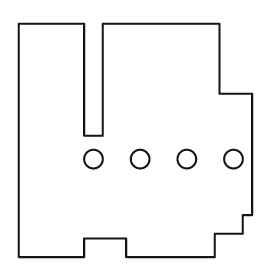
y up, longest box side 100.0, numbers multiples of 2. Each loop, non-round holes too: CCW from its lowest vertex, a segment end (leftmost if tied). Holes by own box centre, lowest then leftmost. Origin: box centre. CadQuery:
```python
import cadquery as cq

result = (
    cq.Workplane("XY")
    .moveTo(-50.0, -50.0)
    .lineTo(-22.0, -50.0)
    .lineTo(-22.0, -42.0)
    .lineTo(-4.0, -42.0)
    .lineTo(-4.0, -50.0)
    .lineTo(34.0, -50.0)
    .lineTo(34.0, -40.0)
    .lineTo(46.0, -40.0)
    .lineTo(46.0, -32.0)
    .lineTo(50.0, -32.0)
    .lineTo(50.0, 20.0)
    .lineTo(36.0, 20.0)
    .lineTo(36.0, 50.0)
    .lineTo(-14.0, 50.0)
    .lineTo(-14.0, 2.0)
    .lineTo(-22.0, 2.0)
    .lineTo(-22.0, 50.0)
    .lineTo(-50.0, 50.0)
    .close()
    .moveTo(-18.0, -8.0)
    .circle(4.0)
    .moveTo(2.0, -8.0)
    .circle(4.0)
    .moveTo(22.0, -8.0)
    .circle(4.0)
    .moveTo(42.0, -8.0)
    .circle(4.0)
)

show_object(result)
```